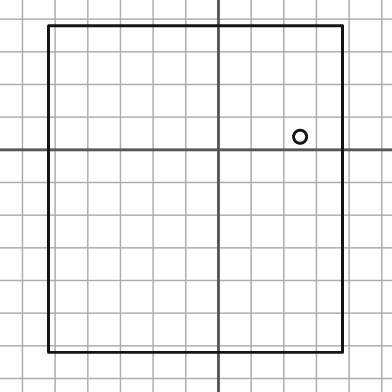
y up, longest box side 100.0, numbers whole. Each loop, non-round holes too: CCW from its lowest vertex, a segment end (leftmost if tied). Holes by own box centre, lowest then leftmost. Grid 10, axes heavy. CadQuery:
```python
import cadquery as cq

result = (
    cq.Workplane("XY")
    .moveTo(-52.0, -62.0)
    .lineTo(38.0, -62.0)
    .lineTo(38.0, 38.0)
    .lineTo(-52.0, 38.0)
    .close()
    .moveTo(25.0, 4.0)
    .circle(2.0)
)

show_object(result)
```